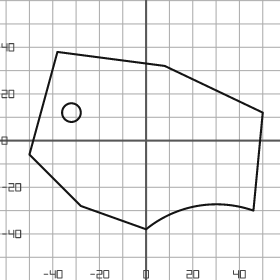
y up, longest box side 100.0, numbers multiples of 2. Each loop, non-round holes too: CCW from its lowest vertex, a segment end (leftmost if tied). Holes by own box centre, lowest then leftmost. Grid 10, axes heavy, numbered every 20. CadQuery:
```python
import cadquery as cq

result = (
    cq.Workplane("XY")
    .moveTo(0.0, -38.0)
    .threePointArc((22.0, -28.0), (46.0, -30.0))
    .lineTo(50.0, 12.0)
    .lineTo(8.0, 32.0)
    .lineTo(-38.0, 38.0)
    .lineTo(-50.0, -6.0)
    .lineTo(-28.0, -28.0)
    .close()
    .moveTo(-32.0, 12.0)
    .circle(4.0)
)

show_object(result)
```